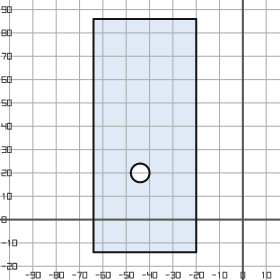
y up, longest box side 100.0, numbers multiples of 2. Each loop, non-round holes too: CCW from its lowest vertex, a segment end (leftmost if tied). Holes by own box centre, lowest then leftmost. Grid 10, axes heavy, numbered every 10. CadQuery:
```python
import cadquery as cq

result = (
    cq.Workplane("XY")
    .moveTo(-64.0, -14.0)
    .lineTo(-20.0, -14.0)
    .lineTo(-20.0, 86.0)
    .lineTo(-64.0, 86.0)
    .close()
    .moveTo(-44.0, 20.0)
    .circle(4.0)
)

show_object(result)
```